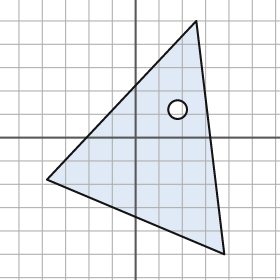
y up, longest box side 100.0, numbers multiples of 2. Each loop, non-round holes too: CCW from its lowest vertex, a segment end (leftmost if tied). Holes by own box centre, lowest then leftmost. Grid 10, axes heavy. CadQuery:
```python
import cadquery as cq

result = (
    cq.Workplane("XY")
    .moveTo(38.0, -50.0)
    .lineTo(26.0, 50.0)
    .lineTo(-38.0, -18.0)
    .close()
    .moveTo(18.0, 12.0)
    .circle(4.0)
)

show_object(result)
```